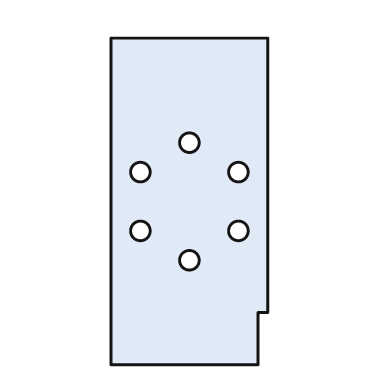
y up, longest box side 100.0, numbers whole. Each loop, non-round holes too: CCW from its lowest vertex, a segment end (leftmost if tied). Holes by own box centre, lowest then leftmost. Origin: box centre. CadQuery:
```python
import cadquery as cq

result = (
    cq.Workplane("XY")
    .moveTo(-24.0, -50.0)
    .lineTo(21.0, -50.0)
    .lineTo(21.0, -34.0)
    .lineTo(24.0, -34.0)
    .lineTo(24.0, 50.0)
    .lineTo(-24.0, 50.0)
    .close()
    .moveTo(0.0, -18.0)
    .circle(3.0)
    .moveTo(-15.0, -9.0)
    .circle(3.0)
    .moveTo(15.0, -9.0)
    .circle(3.0)
    .moveTo(-15.0, 9.0)
    .circle(3.0)
    .moveTo(15.0, 9.0)
    .circle(3.0)
    .moveTo(0.0, 18.0)
    .circle(3.0)
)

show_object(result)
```